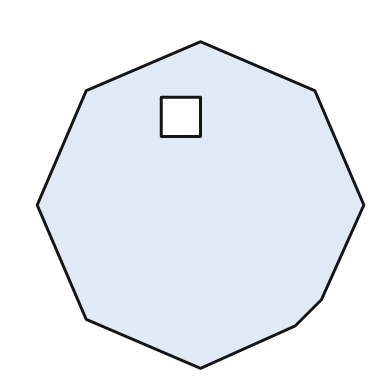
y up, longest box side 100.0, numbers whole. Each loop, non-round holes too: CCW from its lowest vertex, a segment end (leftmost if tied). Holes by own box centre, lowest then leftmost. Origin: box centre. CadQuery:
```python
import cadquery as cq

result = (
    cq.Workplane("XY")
    .moveTo(0.0, -50.0)
    .lineTo(29.0, -37.0)
    .lineTo(37.0, -29.0)
    .lineTo(50.0, 0.0)
    .lineTo(35.0, 35.0)
    .lineTo(0.0, 50.0)
    .lineTo(-35.0, 35.0)
    .lineTo(-50.0, 0.0)
    .lineTo(-35.0, -35.0)
    .close()
    .moveTo(-12.0, 21.0)
    .lineTo(0.0, 21.0)
    .lineTo(0.0, 33.0)
    .lineTo(-12.0, 33.0)
    .close()
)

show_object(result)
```